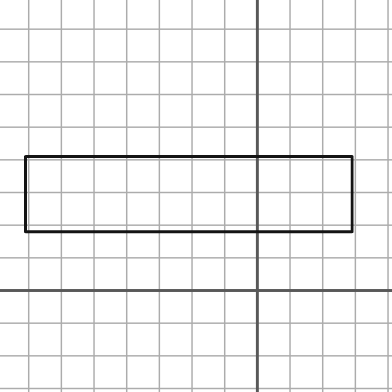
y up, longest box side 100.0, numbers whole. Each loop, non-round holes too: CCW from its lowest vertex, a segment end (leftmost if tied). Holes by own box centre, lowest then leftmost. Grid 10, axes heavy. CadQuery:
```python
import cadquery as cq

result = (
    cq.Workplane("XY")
    .moveTo(-71.0, 18.0)
    .lineTo(29.0, 18.0)
    .lineTo(29.0, 41.0)
    .lineTo(-71.0, 41.0)
    .close()
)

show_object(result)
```